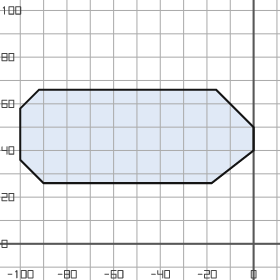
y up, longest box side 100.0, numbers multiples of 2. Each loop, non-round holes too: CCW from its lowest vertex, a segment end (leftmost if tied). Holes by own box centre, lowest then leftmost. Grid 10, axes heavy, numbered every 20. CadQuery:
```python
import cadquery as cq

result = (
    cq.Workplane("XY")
    .moveTo(-90.0, 26.0)
    .lineTo(-18.0, 26.0)
    .lineTo(0.0, 40.0)
    .lineTo(0.0, 50.0)
    .lineTo(-16.0, 66.0)
    .lineTo(-92.0, 66.0)
    .lineTo(-100.0, 58.0)
    .lineTo(-100.0, 36.0)
    .close()
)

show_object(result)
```